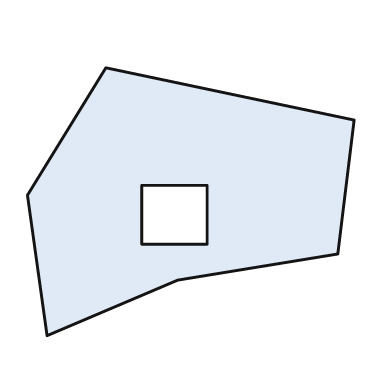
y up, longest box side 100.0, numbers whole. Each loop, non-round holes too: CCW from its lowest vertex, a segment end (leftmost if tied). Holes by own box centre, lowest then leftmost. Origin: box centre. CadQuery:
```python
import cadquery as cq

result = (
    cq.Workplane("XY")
    .moveTo(-44.0, -41.0)
    .lineTo(-4.0, -24.0)
    .lineTo(45.0, -16.0)
    .lineTo(50.0, 25.0)
    .lineTo(-26.0, 41.0)
    .lineTo(-50.0, 2.0)
    .close()
    .moveTo(-15.0, -13.0)
    .lineTo(5.0, -13.0)
    .lineTo(5.0, 5.0)
    .lineTo(-15.0, 5.0)
    .close()
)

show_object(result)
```